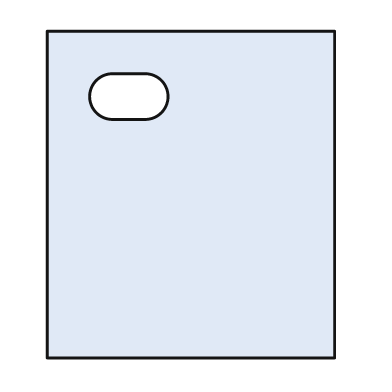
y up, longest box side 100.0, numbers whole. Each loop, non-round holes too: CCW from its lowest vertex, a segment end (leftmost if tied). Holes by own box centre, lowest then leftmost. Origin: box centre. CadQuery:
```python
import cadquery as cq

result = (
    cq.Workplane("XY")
    .moveTo(-44.0, -50.0)
    .lineTo(44.0, -50.0)
    .lineTo(44.0, 50.0)
    .lineTo(-44.0, 50.0)
    .close()
    .moveTo(-24.0, 23.0)
    .lineTo(-14.0, 23.0)
    .threePointArc((-7.0, 30.0), (-14.0, 37.0))
    .lineTo(-24.0, 37.0)
    .threePointArc((-31.0, 30.0), (-24.0, 23.0))
    .close()
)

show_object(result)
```